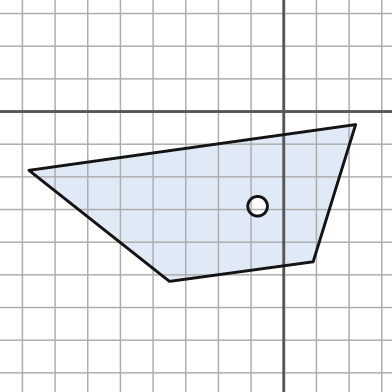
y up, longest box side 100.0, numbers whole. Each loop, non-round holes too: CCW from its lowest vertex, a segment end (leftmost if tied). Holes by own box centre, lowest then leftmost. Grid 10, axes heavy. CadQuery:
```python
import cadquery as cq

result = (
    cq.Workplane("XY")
    .moveTo(-35.0, -52.0)
    .lineTo(9.0, -46.0)
    .lineTo(22.0, -4.0)
    .lineTo(-78.0, -18.0)
    .close()
    .moveTo(-8.0, -29.0)
    .circle(3.0)
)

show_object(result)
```